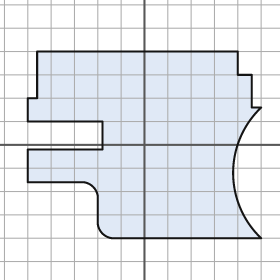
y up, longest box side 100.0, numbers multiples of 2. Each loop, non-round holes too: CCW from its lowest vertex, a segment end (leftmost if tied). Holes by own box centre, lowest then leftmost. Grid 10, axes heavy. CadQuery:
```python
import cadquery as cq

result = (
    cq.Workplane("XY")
    .moveTo(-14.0, -40.0)
    .lineTo(50.0, -40.0)
    .threePointArc((38.0, -12.0), (50.0, 16.0))
    .lineTo(46.0, 16.0)
    .lineTo(46.0, 30.0)
    .lineTo(40.0, 30.0)
    .lineTo(40.0, 40.0)
    .lineTo(-46.0, 40.0)
    .lineTo(-46.0, 20.0)
    .lineTo(-50.0, 20.0)
    .lineTo(-50.0, 10.0)
    .lineTo(-18.0, 10.0)
    .lineTo(-18.0, -2.0)
    .lineTo(-50.0, -2.0)
    .lineTo(-50.0, -16.0)
    .lineTo(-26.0, -16.0)
    .threePointArc((-22.0, -18.0), (-20.0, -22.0))
    .lineTo(-20.0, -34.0)
    .threePointArc((-18.0, -38.0), (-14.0, -40.0))
    .close()
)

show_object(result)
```